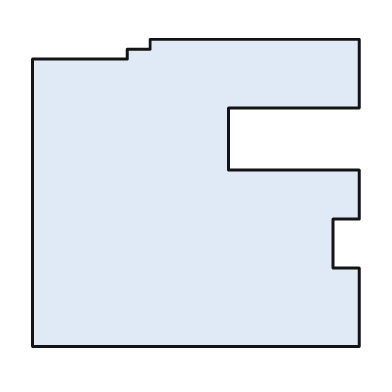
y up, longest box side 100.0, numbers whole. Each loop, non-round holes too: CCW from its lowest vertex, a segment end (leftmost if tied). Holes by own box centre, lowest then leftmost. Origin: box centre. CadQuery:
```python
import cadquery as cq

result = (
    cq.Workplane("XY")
    .moveTo(-50.0, -47.0)
    .lineTo(50.0, -47.0)
    .lineTo(50.0, -23.0)
    .lineTo(42.0, -23.0)
    .lineTo(42.0, -8.0)
    .lineTo(50.0, -8.0)
    .lineTo(50.0, 7.0)
    .lineTo(10.0, 7.0)
    .lineTo(10.0, 26.0)
    .lineTo(50.0, 26.0)
    .lineTo(50.0, 47.0)
    .lineTo(-14.0, 47.0)
    .lineTo(-14.0, 44.0)
    .lineTo(-21.0, 44.0)
    .lineTo(-21.0, 41.0)
    .lineTo(-50.0, 41.0)
    .close()
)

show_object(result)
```